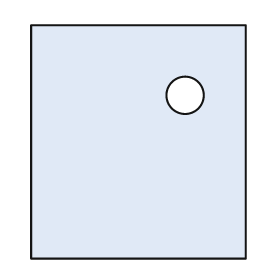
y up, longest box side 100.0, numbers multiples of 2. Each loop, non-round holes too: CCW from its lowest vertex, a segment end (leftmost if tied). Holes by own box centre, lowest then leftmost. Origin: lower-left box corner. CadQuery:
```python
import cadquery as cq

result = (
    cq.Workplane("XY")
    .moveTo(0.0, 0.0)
    .lineTo(92.0, 0.0)
    .lineTo(92.0, 100.0)
    .lineTo(0.0, 100.0)
    .close()
    .moveTo(66.0, 70.0)
    .circle(8.0)
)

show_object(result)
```